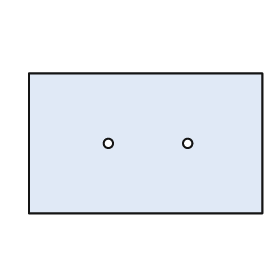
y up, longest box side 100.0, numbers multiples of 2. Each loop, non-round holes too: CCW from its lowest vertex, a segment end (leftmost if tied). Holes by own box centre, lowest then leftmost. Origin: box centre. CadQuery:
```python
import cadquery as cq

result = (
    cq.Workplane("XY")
    .moveTo(-50.0, -30.0)
    .lineTo(50.0, -30.0)
    .lineTo(50.0, 30.0)
    .lineTo(-50.0, 30.0)
    .close()
    .moveTo(-16.0, 0.0)
    .circle(2.0)
    .moveTo(18.0, 0.0)
    .circle(2.0)
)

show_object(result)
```